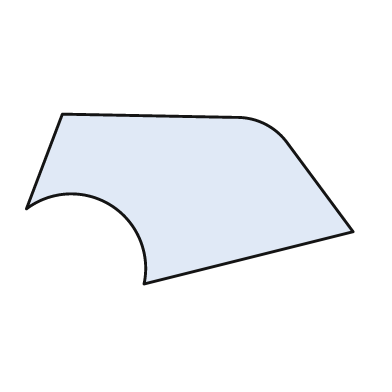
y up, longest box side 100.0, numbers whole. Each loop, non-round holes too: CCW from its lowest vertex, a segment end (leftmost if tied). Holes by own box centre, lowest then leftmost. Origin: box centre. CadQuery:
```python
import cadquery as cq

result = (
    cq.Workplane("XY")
    .moveTo(-14.0, -26.0)
    .lineTo(50.0, -10.0)
    .lineTo(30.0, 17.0)
    .threePointArc((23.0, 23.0), (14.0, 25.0))
    .lineTo(-39.0, 26.0)
    .lineTo(-50.0, -3.0)
    .threePointArc((-24.0, -2.0), (-14.0, -26.0))
    .close()
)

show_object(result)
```